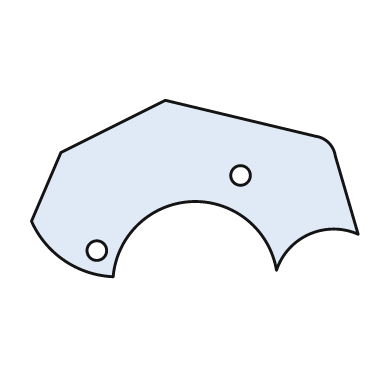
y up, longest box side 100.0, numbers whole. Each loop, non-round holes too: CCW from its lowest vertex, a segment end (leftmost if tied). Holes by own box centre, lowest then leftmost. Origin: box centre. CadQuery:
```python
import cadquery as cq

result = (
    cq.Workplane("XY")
    .moveTo(-25.0, -27.0)
    .threePointArc((-1.0, -4.0), (25.0, -25.0))
    .threePointArc((35.0, -14.0), (50.0, -14.0))
    .lineTo(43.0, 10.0)
    .threePointArc((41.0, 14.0), (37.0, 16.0))
    .lineTo(-9.0, 27.0)
    .lineTo(-41.0, 11.0)
    .lineTo(-50.0, -10.0)
    .threePointArc((-40.0, -22.0), (-25.0, -27.0))
    .close()
    .moveTo(-30.0, -19.0)
    .circle(3.0)
    .moveTo(14.0, 4.0)
    .circle(3.0)
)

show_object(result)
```